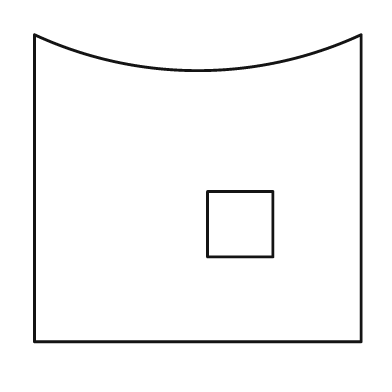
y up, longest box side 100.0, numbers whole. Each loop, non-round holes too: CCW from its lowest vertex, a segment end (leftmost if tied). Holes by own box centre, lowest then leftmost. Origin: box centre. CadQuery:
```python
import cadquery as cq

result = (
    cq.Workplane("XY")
    .moveTo(-50.0, -47.0)
    .lineTo(50.0, -47.0)
    .lineTo(50.0, 47.0)
    .threePointArc((0.0, 36.0), (-50.0, 47.0))
    .close()
    .moveTo(3.0, -21.0)
    .lineTo(23.0, -21.0)
    .lineTo(23.0, -1.0)
    .lineTo(3.0, -1.0)
    .close()
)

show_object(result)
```